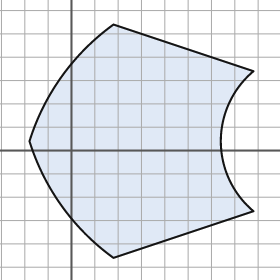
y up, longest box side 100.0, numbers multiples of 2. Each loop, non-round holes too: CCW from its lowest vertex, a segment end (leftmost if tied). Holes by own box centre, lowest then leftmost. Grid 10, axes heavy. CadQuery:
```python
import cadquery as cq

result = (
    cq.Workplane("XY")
    .moveTo(18.0, -46.0)
    .lineTo(78.0, -26.0)
    .threePointArc((64.0, 4.0), (78.0, 34.0))
    .lineTo(18.0, 54.0)
    .threePointArc((-4.0, 32.0), (-18.0, 4.0))
    .threePointArc((-4.0, -24.0), (18.0, -46.0))
    .close()
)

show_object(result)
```